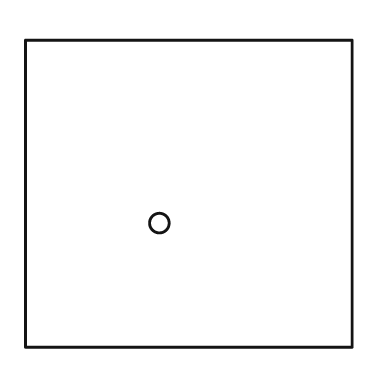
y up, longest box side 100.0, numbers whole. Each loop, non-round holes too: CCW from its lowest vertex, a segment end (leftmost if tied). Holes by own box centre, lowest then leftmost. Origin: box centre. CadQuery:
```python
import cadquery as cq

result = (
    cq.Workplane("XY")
    .moveTo(-50.0, -47.0)
    .lineTo(50.0, -47.0)
    .lineTo(50.0, 47.0)
    .lineTo(-50.0, 47.0)
    .close()
    .moveTo(-9.0, -9.0)
    .circle(3.0)
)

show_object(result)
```